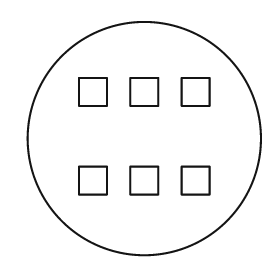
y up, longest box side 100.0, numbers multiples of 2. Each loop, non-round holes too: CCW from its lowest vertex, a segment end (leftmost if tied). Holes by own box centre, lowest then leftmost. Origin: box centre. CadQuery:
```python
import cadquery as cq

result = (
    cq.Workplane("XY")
    .moveTo(0.0, 0.0)
    .circle(50.0)
    .moveTo(-28.0, -24.0)
    .lineTo(-16.0, -24.0)
    .lineTo(-16.0, -12.0)
    .lineTo(-28.0, -12.0)
    .close()
    .moveTo(-6.0, -24.0)
    .lineTo(6.0, -24.0)
    .lineTo(6.0, -12.0)
    .lineTo(-6.0, -12.0)
    .close()
    .moveTo(16.0, -24.0)
    .lineTo(28.0, -24.0)
    .lineTo(28.0, -12.0)
    .lineTo(16.0, -12.0)
    .close()
    .moveTo(-28.0, 14.0)
    .lineTo(-16.0, 14.0)
    .lineTo(-16.0, 26.0)
    .lineTo(-28.0, 26.0)
    .close()
    .moveTo(-6.0, 14.0)
    .lineTo(6.0, 14.0)
    .lineTo(6.0, 26.0)
    .lineTo(-6.0, 26.0)
    .close()
    .moveTo(16.0, 14.0)
    .lineTo(28.0, 14.0)
    .lineTo(28.0, 26.0)
    .lineTo(16.0, 26.0)
    .close()
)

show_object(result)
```